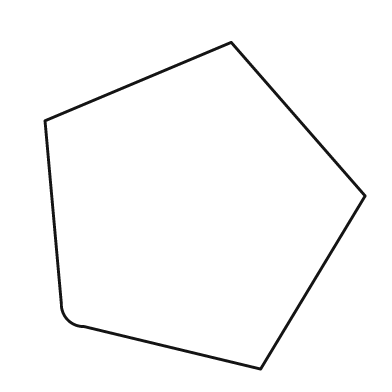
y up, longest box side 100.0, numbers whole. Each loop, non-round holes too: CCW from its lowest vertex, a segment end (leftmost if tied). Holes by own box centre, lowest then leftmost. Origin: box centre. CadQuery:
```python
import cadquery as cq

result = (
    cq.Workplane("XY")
    .moveTo(17.0, -50.0)
    .lineTo(49.0, 3.0)
    .lineTo(8.0, 50.0)
    .lineTo(-49.0, 26.0)
    .lineTo(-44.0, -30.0)
    .threePointArc((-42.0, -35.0), (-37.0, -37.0))
    .close()
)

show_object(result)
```